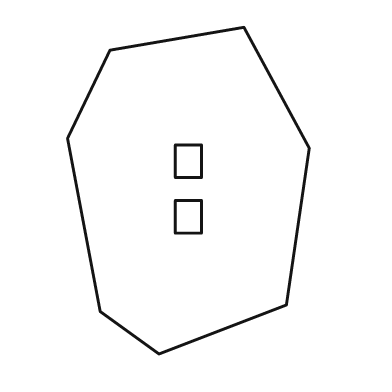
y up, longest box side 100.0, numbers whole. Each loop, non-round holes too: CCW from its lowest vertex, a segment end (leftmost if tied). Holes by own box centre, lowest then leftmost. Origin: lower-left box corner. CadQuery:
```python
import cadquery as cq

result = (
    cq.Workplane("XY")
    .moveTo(28.0, 0.0)
    .lineTo(67.0, 15.0)
    .lineTo(74.0, 63.0)
    .lineTo(54.0, 100.0)
    .lineTo(13.0, 93.0)
    .lineTo(0.0, 66.0)
    .lineTo(10.0, 13.0)
    .close()
    .moveTo(33.0, 37.0)
    .lineTo(41.0, 37.0)
    .lineTo(41.0, 47.0)
    .lineTo(33.0, 47.0)
    .close()
    .moveTo(33.0, 54.0)
    .lineTo(41.0, 54.0)
    .lineTo(41.0, 64.0)
    .lineTo(33.0, 64.0)
    .close()
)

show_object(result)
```